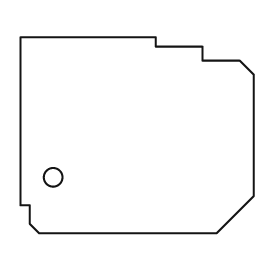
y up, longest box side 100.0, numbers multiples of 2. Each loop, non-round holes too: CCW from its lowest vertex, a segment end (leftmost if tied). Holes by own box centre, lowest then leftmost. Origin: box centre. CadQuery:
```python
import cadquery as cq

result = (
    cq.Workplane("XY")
    .moveTo(-42.0, -42.0)
    .lineTo(34.0, -42.0)
    .lineTo(50.0, -26.0)
    .lineTo(50.0, 26.0)
    .lineTo(44.0, 32.0)
    .lineTo(28.0, 32.0)
    .lineTo(28.0, 38.0)
    .lineTo(8.0, 38.0)
    .lineTo(8.0, 42.0)
    .lineTo(-50.0, 42.0)
    .lineTo(-50.0, -30.0)
    .lineTo(-46.0, -30.0)
    .lineTo(-46.0, -38.0)
    .close()
    .moveTo(-36.0, -18.0)
    .circle(4.0)
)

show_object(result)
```